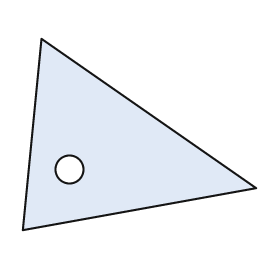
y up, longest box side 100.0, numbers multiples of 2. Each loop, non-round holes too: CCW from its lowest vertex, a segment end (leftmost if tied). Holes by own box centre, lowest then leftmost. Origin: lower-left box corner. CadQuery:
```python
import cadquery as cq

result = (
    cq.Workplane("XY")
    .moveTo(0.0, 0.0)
    .lineTo(100.0, 18.0)
    .lineTo(8.0, 82.0)
    .close()
    .moveTo(20.0, 26.0)
    .circle(6.0)
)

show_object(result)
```